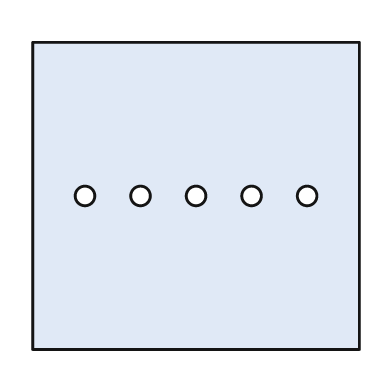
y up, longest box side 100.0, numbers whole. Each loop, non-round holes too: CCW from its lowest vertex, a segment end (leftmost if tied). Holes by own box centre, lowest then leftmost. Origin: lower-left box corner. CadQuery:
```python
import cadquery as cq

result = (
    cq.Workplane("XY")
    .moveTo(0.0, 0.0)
    .lineTo(100.0, 0.0)
    .lineTo(100.0, 94.0)
    .lineTo(0.0, 94.0)
    .close()
    .moveTo(16.0, 47.0)
    .circle(3.0)
    .moveTo(33.0, 47.0)
    .circle(3.0)
    .moveTo(50.0, 47.0)
    .circle(3.0)
    .moveTo(67.0, 47.0)
    .circle(3.0)
    .moveTo(84.0, 47.0)
    .circle(3.0)
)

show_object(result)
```